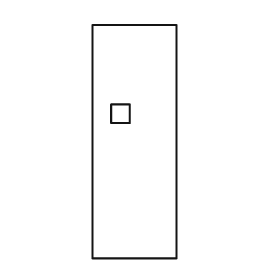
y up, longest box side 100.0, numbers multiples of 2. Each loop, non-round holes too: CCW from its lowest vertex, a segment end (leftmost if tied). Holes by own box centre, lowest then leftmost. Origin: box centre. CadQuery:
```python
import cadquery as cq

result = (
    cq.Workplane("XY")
    .moveTo(-18.0, -50.0)
    .lineTo(18.0, -50.0)
    .lineTo(18.0, 50.0)
    .lineTo(-18.0, 50.0)
    .close()
    .moveTo(-10.0, 8.0)
    .lineTo(-2.0, 8.0)
    .lineTo(-2.0, 16.0)
    .lineTo(-10.0, 16.0)
    .close()
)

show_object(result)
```